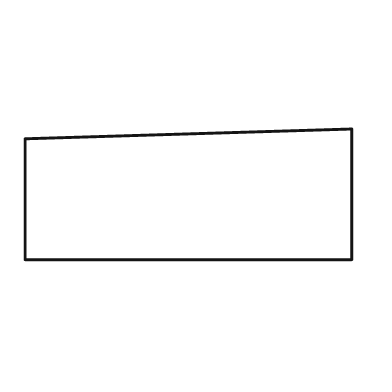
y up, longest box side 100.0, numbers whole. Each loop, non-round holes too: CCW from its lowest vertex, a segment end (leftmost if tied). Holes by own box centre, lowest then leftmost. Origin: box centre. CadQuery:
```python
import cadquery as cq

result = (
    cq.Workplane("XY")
    .moveTo(-50.0, -20.0)
    .lineTo(50.0, -20.0)
    .lineTo(50.0, 20.0)
    .lineTo(-50.0, 17.0)
    .close()
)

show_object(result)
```